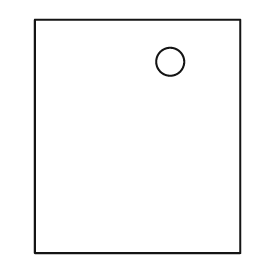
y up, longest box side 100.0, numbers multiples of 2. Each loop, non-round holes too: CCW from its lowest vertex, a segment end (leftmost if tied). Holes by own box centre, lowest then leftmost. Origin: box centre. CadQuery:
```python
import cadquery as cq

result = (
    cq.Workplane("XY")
    .moveTo(-44.0, -50.0)
    .lineTo(44.0, -50.0)
    .lineTo(44.0, 50.0)
    .lineTo(-44.0, 50.0)
    .close()
    .moveTo(14.0, 32.0)
    .circle(6.0)
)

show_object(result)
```